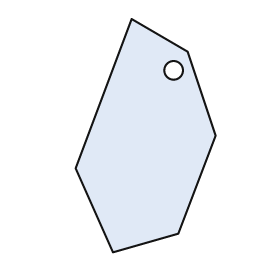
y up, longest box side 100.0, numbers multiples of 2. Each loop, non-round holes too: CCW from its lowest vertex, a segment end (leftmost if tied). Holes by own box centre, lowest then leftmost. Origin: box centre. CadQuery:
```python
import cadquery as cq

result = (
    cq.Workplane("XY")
    .moveTo(-14.0, -50.0)
    .lineTo(14.0, -42.0)
    .lineTo(30.0, 0.0)
    .lineTo(18.0, 36.0)
    .lineTo(-6.0, 50.0)
    .lineTo(-30.0, -14.0)
    .close()
    .moveTo(12.0, 28.0)
    .circle(4.0)
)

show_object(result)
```